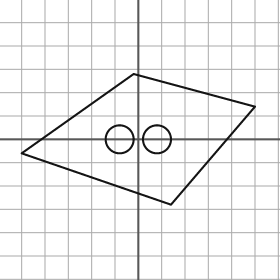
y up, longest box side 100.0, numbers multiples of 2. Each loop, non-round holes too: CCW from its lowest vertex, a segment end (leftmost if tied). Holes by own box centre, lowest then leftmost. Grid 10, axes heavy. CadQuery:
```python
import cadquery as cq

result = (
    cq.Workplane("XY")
    .moveTo(14.0, -28.0)
    .lineTo(50.0, 14.0)
    .lineTo(-2.0, 28.0)
    .lineTo(-50.0, -6.0)
    .close()
    .moveTo(-8.0, 0.0)
    .circle(6.0)
    .moveTo(8.0, 0.0)
    .circle(6.0)
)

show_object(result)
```